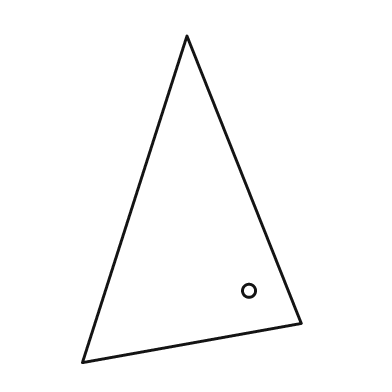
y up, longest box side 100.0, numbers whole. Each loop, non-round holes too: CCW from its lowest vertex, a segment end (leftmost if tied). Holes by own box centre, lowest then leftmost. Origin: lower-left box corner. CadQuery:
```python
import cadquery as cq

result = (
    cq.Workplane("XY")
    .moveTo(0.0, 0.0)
    .lineTo(67.0, 12.0)
    .lineTo(32.0, 100.0)
    .close()
    .moveTo(51.0, 22.0)
    .circle(2.0)
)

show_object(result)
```